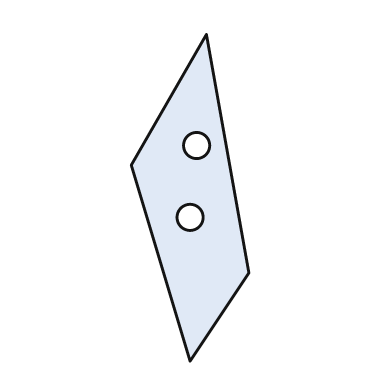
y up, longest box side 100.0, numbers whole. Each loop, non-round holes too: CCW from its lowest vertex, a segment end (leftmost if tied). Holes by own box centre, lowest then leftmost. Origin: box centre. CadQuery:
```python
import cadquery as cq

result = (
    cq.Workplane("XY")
    .moveTo(0.0, -50.0)
    .lineTo(18.0, -23.0)
    .lineTo(5.0, 50.0)
    .lineTo(-18.0, 10.0)
    .close()
    .moveTo(0.0, -6.0)
    .circle(4.0)
    .moveTo(2.0, 16.0)
    .circle(4.0)
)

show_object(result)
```